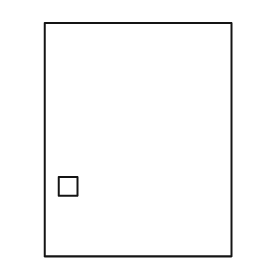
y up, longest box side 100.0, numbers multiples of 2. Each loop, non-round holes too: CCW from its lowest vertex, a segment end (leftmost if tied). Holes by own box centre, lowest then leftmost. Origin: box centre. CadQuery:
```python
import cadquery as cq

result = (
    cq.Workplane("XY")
    .moveTo(-40.0, -50.0)
    .lineTo(40.0, -50.0)
    .lineTo(40.0, 50.0)
    .lineTo(-40.0, 50.0)
    .close()
    .moveTo(-34.0, -24.0)
    .lineTo(-26.0, -24.0)
    .lineTo(-26.0, -16.0)
    .lineTo(-34.0, -16.0)
    .close()
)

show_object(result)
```